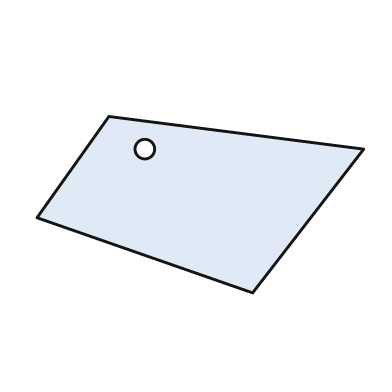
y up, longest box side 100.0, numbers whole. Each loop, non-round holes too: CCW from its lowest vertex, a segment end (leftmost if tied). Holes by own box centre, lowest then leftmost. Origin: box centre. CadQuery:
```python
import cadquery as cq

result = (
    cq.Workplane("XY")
    .moveTo(16.0, -27.0)
    .lineTo(50.0, 17.0)
    .lineTo(-28.0, 27.0)
    .lineTo(-50.0, -4.0)
    .close()
    .moveTo(-17.0, 17.0)
    .circle(3.0)
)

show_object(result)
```